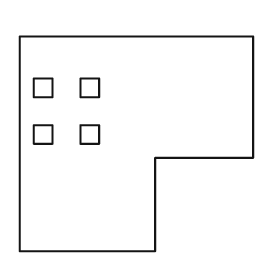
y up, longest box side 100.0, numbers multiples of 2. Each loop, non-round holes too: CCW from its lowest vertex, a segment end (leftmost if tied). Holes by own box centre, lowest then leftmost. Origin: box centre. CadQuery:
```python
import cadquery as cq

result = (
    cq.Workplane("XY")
    .moveTo(-50.0, -46.0)
    .lineTo(8.0, -46.0)
    .lineTo(8.0, -6.0)
    .lineTo(50.0, -6.0)
    .lineTo(50.0, 46.0)
    .lineTo(-50.0, 46.0)
    .close()
    .moveTo(-44.0, 0.0)
    .lineTo(-36.0, 0.0)
    .lineTo(-36.0, 8.0)
    .lineTo(-44.0, 8.0)
    .close()
    .moveTo(-24.0, 0.0)
    .lineTo(-16.0, 0.0)
    .lineTo(-16.0, 8.0)
    .lineTo(-24.0, 8.0)
    .close()
    .moveTo(-44.0, 20.0)
    .lineTo(-36.0, 20.0)
    .lineTo(-36.0, 28.0)
    .lineTo(-44.0, 28.0)
    .close()
    .moveTo(-24.0, 20.0)
    .lineTo(-16.0, 20.0)
    .lineTo(-16.0, 28.0)
    .lineTo(-24.0, 28.0)
    .close()
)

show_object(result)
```